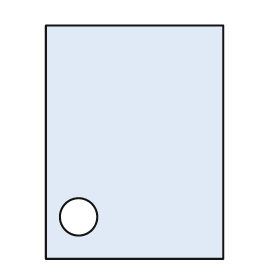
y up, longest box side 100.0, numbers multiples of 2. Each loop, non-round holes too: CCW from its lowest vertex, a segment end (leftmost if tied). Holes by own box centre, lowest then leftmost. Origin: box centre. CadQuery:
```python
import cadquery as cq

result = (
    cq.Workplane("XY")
    .moveTo(-38.0, -50.0)
    .lineTo(38.0, -50.0)
    .lineTo(38.0, 50.0)
    .lineTo(-38.0, 50.0)
    .close()
    .moveTo(-24.0, -32.0)
    .circle(8.0)
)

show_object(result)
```